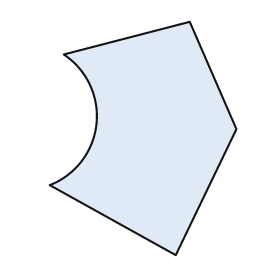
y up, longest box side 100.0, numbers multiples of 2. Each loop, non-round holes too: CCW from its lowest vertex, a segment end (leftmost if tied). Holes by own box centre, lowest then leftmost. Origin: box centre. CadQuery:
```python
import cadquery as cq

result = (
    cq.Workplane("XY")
    .moveTo(14.0, -50.0)
    .lineTo(40.0, 4.0)
    .lineTo(20.0, 50.0)
    .lineTo(-34.0, 36.0)
    .threePointArc((-20.0, 6.0), (-40.0, -20.0))
    .close()
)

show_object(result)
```